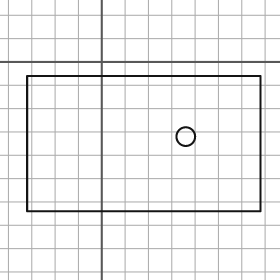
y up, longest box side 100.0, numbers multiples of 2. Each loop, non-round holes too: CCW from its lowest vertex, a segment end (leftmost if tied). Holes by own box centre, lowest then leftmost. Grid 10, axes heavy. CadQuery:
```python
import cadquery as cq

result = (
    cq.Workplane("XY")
    .moveTo(-32.0, -64.0)
    .lineTo(68.0, -64.0)
    .lineTo(68.0, -6.0)
    .lineTo(-32.0, -6.0)
    .close()
    .moveTo(36.0, -32.0)
    .circle(4.0)
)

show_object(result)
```